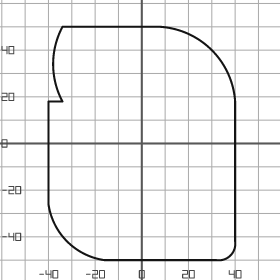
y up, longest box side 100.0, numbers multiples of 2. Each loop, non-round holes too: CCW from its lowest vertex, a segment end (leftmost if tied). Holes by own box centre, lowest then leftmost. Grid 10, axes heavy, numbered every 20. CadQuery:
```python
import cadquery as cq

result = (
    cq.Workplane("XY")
    .moveTo(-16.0, -50.0)
    .lineTo(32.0, -50.0)
    .threePointArc((38.0, -48.0), (40.0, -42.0))
    .lineTo(40.0, 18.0)
    .threePointArc((30.0, 40.0), (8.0, 50.0))
    .lineTo(-34.0, 50.0)
    .threePointArc((-38.0, 34.0), (-34.0, 18.0))
    .lineTo(-40.0, 18.0)
    .lineTo(-40.0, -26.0)
    .threePointArc((-32.0, -42.0), (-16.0, -50.0))
    .close()
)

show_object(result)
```